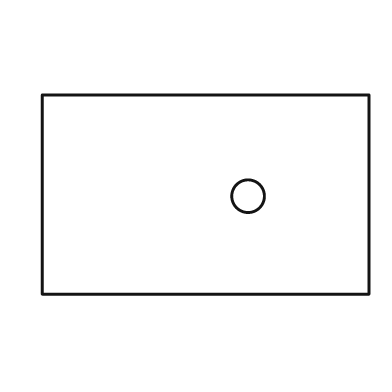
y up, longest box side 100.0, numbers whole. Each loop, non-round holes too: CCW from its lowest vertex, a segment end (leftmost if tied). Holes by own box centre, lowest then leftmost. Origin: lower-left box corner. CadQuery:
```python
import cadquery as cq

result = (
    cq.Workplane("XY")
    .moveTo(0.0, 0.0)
    .lineTo(100.0, 0.0)
    .lineTo(100.0, 61.0)
    .lineTo(0.0, 61.0)
    .close()
    .moveTo(63.0, 30.0)
    .circle(5.0)
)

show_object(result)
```